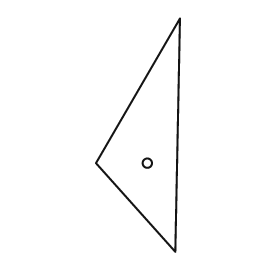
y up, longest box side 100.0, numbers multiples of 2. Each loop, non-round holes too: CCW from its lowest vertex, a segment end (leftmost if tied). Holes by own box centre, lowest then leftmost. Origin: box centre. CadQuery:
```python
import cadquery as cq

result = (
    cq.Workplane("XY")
    .moveTo(16.0, -50.0)
    .lineTo(18.0, 50.0)
    .lineTo(-18.0, -12.0)
    .close()
    .moveTo(4.0, -12.0)
    .circle(2.0)
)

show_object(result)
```